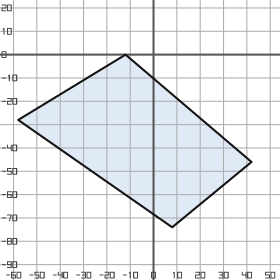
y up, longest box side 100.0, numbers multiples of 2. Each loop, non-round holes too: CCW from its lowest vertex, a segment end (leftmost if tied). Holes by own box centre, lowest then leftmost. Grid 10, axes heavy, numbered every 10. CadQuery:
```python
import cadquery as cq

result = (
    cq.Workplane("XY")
    .moveTo(8.0, -74.0)
    .lineTo(42.0, -46.0)
    .lineTo(-12.0, 0.0)
    .lineTo(-58.0, -28.0)
    .close()
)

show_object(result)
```